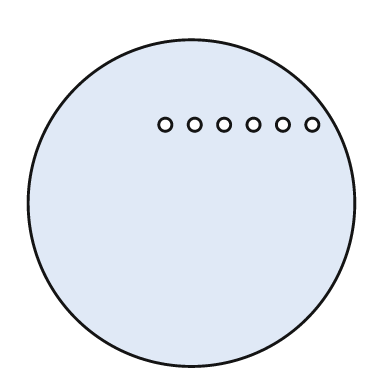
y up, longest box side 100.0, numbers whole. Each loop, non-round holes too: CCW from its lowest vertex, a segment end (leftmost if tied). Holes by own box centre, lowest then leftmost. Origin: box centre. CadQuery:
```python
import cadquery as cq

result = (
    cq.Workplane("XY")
    .moveTo(0.0, 0.0)
    .circle(50.0)
    .moveTo(-8.0, 24.0)
    .circle(2.0)
    .moveTo(1.0, 24.0)
    .circle(2.0)
    .moveTo(10.0, 24.0)
    .circle(2.0)
    .moveTo(19.0, 24.0)
    .circle(2.0)
    .moveTo(28.0, 24.0)
    .circle(2.0)
    .moveTo(37.0, 24.0)
    .circle(2.0)
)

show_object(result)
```